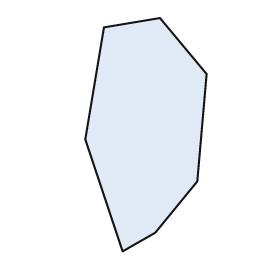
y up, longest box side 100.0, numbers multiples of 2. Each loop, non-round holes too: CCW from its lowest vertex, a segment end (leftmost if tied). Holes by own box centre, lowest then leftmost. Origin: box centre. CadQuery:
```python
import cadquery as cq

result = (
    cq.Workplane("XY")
    .moveTo(-10.0, -50.0)
    .lineTo(4.0, -42.0)
    .lineTo(22.0, -20.0)
    .lineTo(26.0, 26.0)
    .lineTo(6.0, 50.0)
    .lineTo(-18.0, 46.0)
    .lineTo(-26.0, -2.0)
    .close()
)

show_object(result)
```